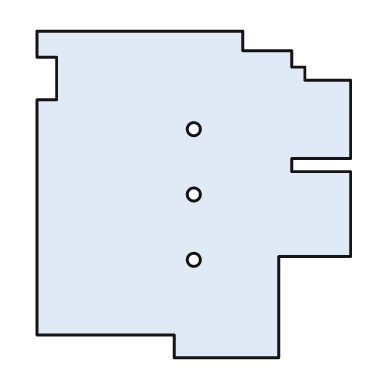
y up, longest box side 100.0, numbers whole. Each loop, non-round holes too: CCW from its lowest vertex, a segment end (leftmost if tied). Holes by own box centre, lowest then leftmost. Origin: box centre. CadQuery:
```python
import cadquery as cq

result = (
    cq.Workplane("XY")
    .moveTo(-6.0, -50.0)
    .lineTo(26.0, -50.0)
    .lineTo(26.0, -19.0)
    .lineTo(48.0, -19.0)
    .lineTo(48.0, 7.0)
    .lineTo(30.0, 7.0)
    .lineTo(30.0, 11.0)
    .lineTo(48.0, 11.0)
    .lineTo(48.0, 35.0)
    .lineTo(34.0, 35.0)
    .lineTo(34.0, 39.0)
    .lineTo(30.0, 39.0)
    .lineTo(30.0, 44.0)
    .lineTo(15.0, 44.0)
    .lineTo(15.0, 50.0)
    .lineTo(-48.0, 50.0)
    .lineTo(-48.0, 42.0)
    .lineTo(-42.0, 42.0)
    .lineTo(-42.0, 29.0)
    .lineTo(-48.0, 29.0)
    .lineTo(-48.0, -43.0)
    .lineTo(-6.0, -43.0)
    .close()
    .moveTo(0.0, -20.0)
    .circle(2.0)
    .moveTo(0.0, 0.0)
    .circle(2.0)
    .moveTo(0.0, 20.0)
    .circle(2.0)
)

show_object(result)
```